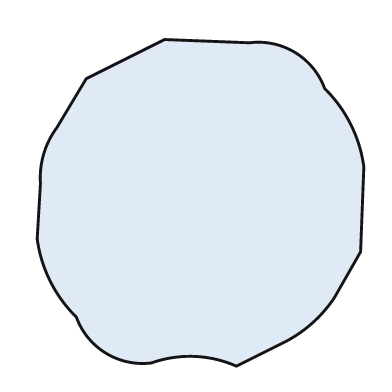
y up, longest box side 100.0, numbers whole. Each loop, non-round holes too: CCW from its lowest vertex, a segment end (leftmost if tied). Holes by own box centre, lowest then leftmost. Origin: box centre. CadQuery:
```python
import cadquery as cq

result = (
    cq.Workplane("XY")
    .moveTo(11.0, -50.0)
    .lineTo(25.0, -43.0)
    .threePointArc((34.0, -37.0), (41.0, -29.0))
    .lineTo(49.0, -15.0)
    .lineTo(50.0, 11.0)
    .threePointArc((46.0, 24.0), (38.0, 35.0))
    .threePointArc((29.0, 46.0), (15.0, 49.0))
    .lineTo(-11.0, 50.0)
    .lineTo(-35.0, 38.0)
    .lineTo(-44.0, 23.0)
    .threePointArc((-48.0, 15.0), (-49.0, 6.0))
    .lineTo(-50.0, -11.0)
    .threePointArc((-46.0, -24.0), (-38.0, -35.0))
    .threePointArc((-29.0, -46.0), (-15.0, -49.0))
    .threePointArc((-2.0, -47.0), (11.0, -50.0))
    .close()
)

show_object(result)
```